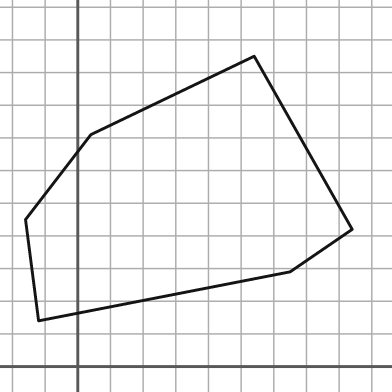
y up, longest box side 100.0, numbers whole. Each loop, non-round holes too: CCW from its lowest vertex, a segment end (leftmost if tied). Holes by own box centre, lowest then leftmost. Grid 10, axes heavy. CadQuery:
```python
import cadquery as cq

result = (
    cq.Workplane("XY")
    .moveTo(-12.0, 14.0)
    .lineTo(65.0, 29.0)
    .lineTo(84.0, 42.0)
    .lineTo(54.0, 95.0)
    .lineTo(4.0, 71.0)
    .lineTo(-16.0, 45.0)
    .close()
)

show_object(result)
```